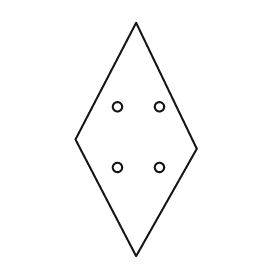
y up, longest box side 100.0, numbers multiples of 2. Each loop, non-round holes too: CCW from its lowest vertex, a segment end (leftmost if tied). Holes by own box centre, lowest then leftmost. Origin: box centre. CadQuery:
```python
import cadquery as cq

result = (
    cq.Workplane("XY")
    .moveTo(0.0, -50.0)
    .lineTo(26.0, -4.0)
    .lineTo(0.0, 50.0)
    .lineTo(-26.0, 0.0)
    .close()
    .moveTo(-8.0, -12.0)
    .circle(2.0)
    .moveTo(10.0, -12.0)
    .circle(2.0)
    .moveTo(-8.0, 14.0)
    .circle(2.0)
    .moveTo(10.0, 14.0)
    .circle(2.0)
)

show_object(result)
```